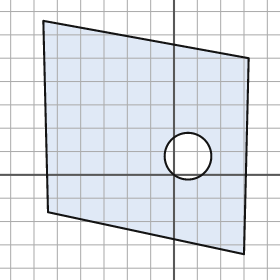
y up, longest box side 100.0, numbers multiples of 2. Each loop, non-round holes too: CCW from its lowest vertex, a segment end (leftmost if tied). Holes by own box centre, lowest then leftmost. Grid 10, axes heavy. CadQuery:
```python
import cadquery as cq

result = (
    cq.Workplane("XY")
    .moveTo(30.0, -34.0)
    .lineTo(32.0, 50.0)
    .lineTo(-56.0, 66.0)
    .lineTo(-54.0, -16.0)
    .close()
    .moveTo(6.0, 8.0)
    .circle(10.0)
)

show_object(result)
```